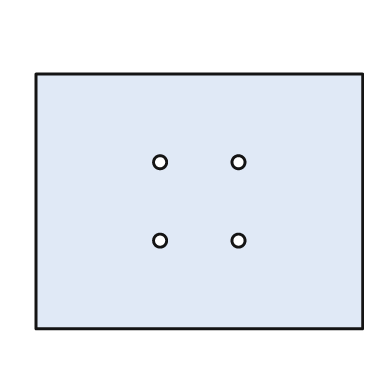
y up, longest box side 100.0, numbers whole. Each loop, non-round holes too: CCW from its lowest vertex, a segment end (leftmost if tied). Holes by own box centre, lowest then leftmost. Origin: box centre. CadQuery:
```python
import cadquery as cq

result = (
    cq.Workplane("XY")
    .moveTo(-50.0, -39.0)
    .lineTo(50.0, -39.0)
    .lineTo(50.0, 39.0)
    .lineTo(-50.0, 39.0)
    .close()
    .moveTo(-12.0, -12.0)
    .circle(2.0)
    .moveTo(12.0, -12.0)
    .circle(2.0)
    .moveTo(-12.0, 12.0)
    .circle(2.0)
    .moveTo(12.0, 12.0)
    .circle(2.0)
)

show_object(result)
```